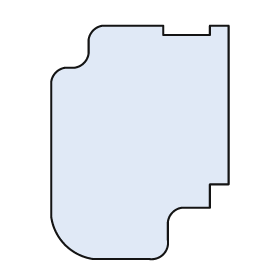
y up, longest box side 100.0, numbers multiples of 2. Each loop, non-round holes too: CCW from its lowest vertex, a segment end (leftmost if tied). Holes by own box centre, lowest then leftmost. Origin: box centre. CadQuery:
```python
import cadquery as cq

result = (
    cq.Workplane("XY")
    .moveTo(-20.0, -50.0)
    .lineTo(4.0, -50.0)
    .threePointArc((10.0, -48.0), (12.0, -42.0))
    .lineTo(12.0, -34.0)
    .threePointArc((14.0, -30.0), (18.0, -28.0))
    .lineTo(30.0, -28.0)
    .lineTo(30.0, -18.0)
    .lineTo(38.0, -18.0)
    .lineTo(38.0, 50.0)
    .lineTo(30.0, 50.0)
    .lineTo(30.0, 46.0)
    .lineTo(10.0, 46.0)
    .lineTo(10.0, 50.0)
    .lineTo(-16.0, 50.0)
    .threePointArc((-20.0, 48.0), (-22.0, 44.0))
    .lineTo(-22.0, 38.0)
    .threePointArc((-24.0, 34.0), (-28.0, 32.0))
    .lineTo(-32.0, 32.0)
    .threePointArc((-36.0, 30.0), (-38.0, 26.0))
    .lineTo(-38.0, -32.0)
    .threePointArc((-32.0, -44.0), (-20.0, -50.0))
    .close()
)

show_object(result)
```